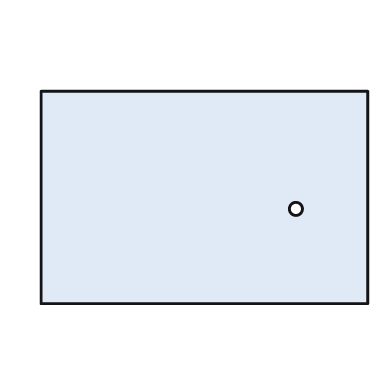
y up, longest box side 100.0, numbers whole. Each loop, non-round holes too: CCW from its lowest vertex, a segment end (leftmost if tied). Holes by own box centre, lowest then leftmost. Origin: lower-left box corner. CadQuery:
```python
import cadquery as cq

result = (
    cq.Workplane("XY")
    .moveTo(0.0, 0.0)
    .lineTo(100.0, 0.0)
    .lineTo(100.0, 65.0)
    .lineTo(0.0, 65.0)
    .close()
    .moveTo(78.0, 29.0)
    .circle(2.0)
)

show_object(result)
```